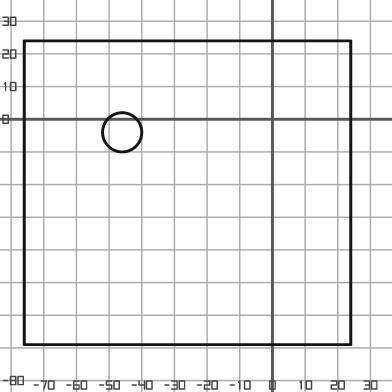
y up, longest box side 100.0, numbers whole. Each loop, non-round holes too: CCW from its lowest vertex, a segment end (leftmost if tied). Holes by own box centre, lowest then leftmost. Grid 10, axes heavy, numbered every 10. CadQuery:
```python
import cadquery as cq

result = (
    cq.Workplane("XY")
    .moveTo(-76.0, -69.0)
    .lineTo(24.0, -69.0)
    .lineTo(24.0, 24.0)
    .lineTo(-76.0, 24.0)
    .close()
    .moveTo(-46.0, -4.0)
    .circle(6.0)
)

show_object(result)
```